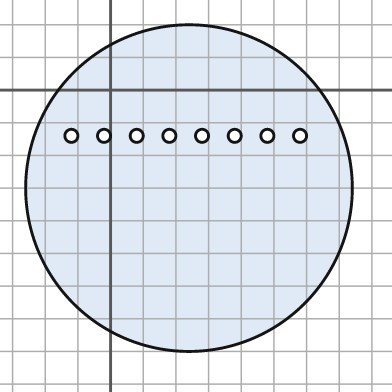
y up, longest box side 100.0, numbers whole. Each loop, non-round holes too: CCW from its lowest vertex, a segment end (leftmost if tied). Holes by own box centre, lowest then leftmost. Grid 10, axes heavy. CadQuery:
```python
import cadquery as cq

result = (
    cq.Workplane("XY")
    .moveTo(24.0, -30.0)
    .circle(50.0)
    .moveTo(-12.0, -14.0)
    .circle(2.0)
    .moveTo(-2.0, -14.0)
    .circle(2.0)
    .moveTo(8.0, -14.0)
    .circle(2.0)
    .moveTo(18.0, -14.0)
    .circle(2.0)
    .moveTo(28.0, -14.0)
    .circle(2.0)
    .moveTo(38.0, -14.0)
    .circle(2.0)
    .moveTo(48.0, -14.0)
    .circle(2.0)
    .moveTo(58.0, -14.0)
    .circle(2.0)
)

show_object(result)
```